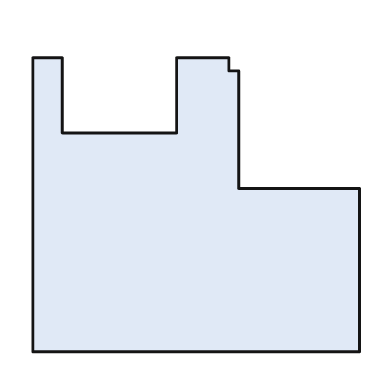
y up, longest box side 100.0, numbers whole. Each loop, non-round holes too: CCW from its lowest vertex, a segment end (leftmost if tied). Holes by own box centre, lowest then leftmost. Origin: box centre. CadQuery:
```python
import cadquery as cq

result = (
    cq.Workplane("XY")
    .moveTo(-50.0, -45.0)
    .lineTo(50.0, -45.0)
    .lineTo(50.0, 5.0)
    .lineTo(13.0, 5.0)
    .lineTo(13.0, 41.0)
    .lineTo(10.0, 41.0)
    .lineTo(10.0, 45.0)
    .lineTo(-6.0, 45.0)
    .lineTo(-6.0, 22.0)
    .lineTo(-41.0, 22.0)
    .lineTo(-41.0, 45.0)
    .lineTo(-50.0, 45.0)
    .close()
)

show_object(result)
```